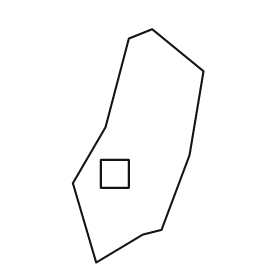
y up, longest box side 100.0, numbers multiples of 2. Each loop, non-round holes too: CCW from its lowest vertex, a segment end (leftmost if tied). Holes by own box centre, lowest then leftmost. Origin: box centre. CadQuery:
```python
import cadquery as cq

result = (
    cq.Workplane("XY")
    .moveTo(-18.0, -50.0)
    .lineTo(2.0, -38.0)
    .lineTo(10.0, -36.0)
    .lineTo(22.0, -4.0)
    .lineTo(28.0, 32.0)
    .lineTo(6.0, 50.0)
    .lineTo(-4.0, 46.0)
    .lineTo(-14.0, 8.0)
    .lineTo(-28.0, -16.0)
    .close()
    .moveTo(-16.0, -18.0)
    .lineTo(-4.0, -18.0)
    .lineTo(-4.0, -6.0)
    .lineTo(-16.0, -6.0)
    .close()
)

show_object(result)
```